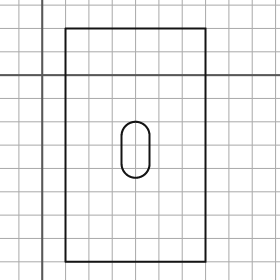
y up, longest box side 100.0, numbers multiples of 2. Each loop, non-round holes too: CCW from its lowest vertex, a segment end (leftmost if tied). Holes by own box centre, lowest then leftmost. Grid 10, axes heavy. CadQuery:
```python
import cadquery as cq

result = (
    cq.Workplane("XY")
    .moveTo(10.0, -80.0)
    .lineTo(70.0, -80.0)
    .lineTo(70.0, 20.0)
    .lineTo(10.0, 20.0)
    .close()
    .moveTo(34.0, -38.0)
    .threePointArc((40.0, -44.0), (46.0, -38.0))
    .lineTo(46.0, -26.0)
    .threePointArc((40.0, -20.0), (34.0, -26.0))
    .close()
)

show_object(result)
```